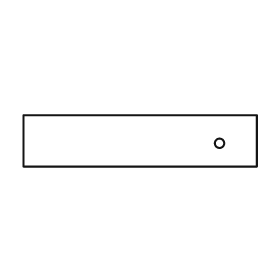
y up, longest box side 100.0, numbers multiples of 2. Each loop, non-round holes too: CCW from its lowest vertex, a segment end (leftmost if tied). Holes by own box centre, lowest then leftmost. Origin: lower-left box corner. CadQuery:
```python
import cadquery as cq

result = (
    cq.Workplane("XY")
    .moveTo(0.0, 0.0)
    .lineTo(100.0, 0.0)
    .lineTo(100.0, 22.0)
    .lineTo(0.0, 22.0)
    .close()
    .moveTo(84.0, 10.0)
    .circle(2.0)
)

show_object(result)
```